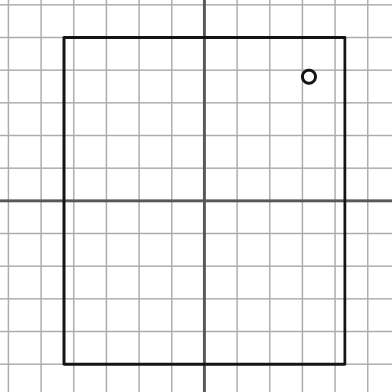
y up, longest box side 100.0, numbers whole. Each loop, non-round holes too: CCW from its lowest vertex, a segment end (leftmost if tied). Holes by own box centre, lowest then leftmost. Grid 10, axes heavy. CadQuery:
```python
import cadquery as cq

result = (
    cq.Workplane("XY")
    .moveTo(-43.0, -50.0)
    .lineTo(43.0, -50.0)
    .lineTo(43.0, 50.0)
    .lineTo(-43.0, 50.0)
    .close()
    .moveTo(32.0, 38.0)
    .circle(2.0)
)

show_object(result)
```